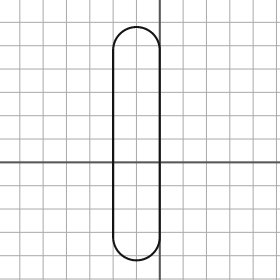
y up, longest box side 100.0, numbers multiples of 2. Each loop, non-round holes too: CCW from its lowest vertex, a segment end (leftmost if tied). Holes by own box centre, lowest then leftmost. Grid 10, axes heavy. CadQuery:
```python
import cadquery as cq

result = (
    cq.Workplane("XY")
    .moveTo(-20.0, -32.0)
    .threePointArc((-10.0, -42.0), (0.0, -32.0))
    .lineTo(0.0, 48.0)
    .threePointArc((-10.0, 58.0), (-20.0, 48.0))
    .close()
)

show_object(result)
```